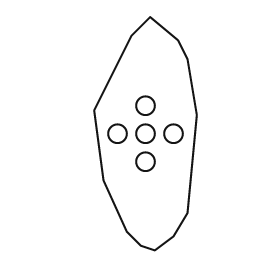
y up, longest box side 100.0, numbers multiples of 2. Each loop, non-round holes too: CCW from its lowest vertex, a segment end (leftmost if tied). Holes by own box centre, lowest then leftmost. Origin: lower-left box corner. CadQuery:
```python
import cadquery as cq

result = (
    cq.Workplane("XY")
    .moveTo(26.0, 0.0)
    .lineTo(34.0, 6.0)
    .lineTo(40.0, 16.0)
    .lineTo(44.0, 58.0)
    .lineTo(40.0, 82.0)
    .lineTo(36.0, 90.0)
    .lineTo(24.0, 100.0)
    .lineTo(16.0, 92.0)
    .lineTo(0.0, 60.0)
    .lineTo(4.0, 30.0)
    .lineTo(14.0, 8.0)
    .lineTo(20.0, 2.0)
    .close()
    .moveTo(22.0, 38.0)
    .circle(4.0)
    .moveTo(10.0, 50.0)
    .circle(4.0)
    .moveTo(22.0, 50.0)
    .circle(4.0)
    .moveTo(34.0, 50.0)
    .circle(4.0)
    .moveTo(22.0, 62.0)
    .circle(4.0)
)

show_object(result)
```